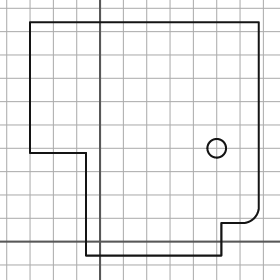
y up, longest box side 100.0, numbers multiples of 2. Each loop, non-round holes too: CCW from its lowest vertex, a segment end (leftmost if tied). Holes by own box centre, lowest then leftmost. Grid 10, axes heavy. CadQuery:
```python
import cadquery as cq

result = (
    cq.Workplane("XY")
    .moveTo(-6.0, -6.0)
    .lineTo(52.0, -6.0)
    .lineTo(52.0, 8.0)
    .lineTo(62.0, 8.0)
    .threePointArc((66.0, 10.0), (68.0, 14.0))
    .lineTo(68.0, 94.0)
    .lineTo(-30.0, 94.0)
    .lineTo(-30.0, 38.0)
    .lineTo(-6.0, 38.0)
    .close()
    .moveTo(50.0, 40.0)
    .circle(4.0)
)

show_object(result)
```